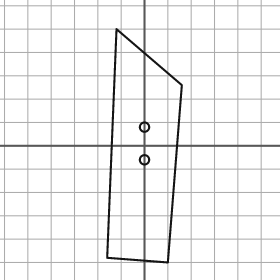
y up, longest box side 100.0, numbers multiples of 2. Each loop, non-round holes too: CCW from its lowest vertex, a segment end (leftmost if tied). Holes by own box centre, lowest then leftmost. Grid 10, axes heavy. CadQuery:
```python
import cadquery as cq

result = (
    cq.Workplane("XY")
    .moveTo(10.0, -50.0)
    .lineTo(16.0, 26.0)
    .lineTo(-12.0, 50.0)
    .lineTo(-16.0, -48.0)
    .close()
    .moveTo(0.0, -6.0)
    .circle(2.0)
    .moveTo(0.0, 8.0)
    .circle(2.0)
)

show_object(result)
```